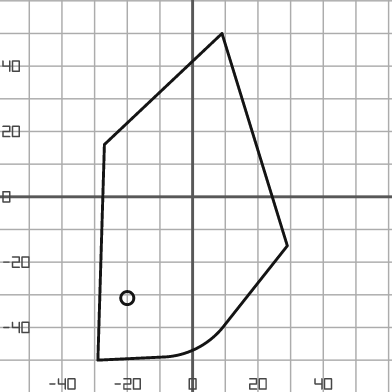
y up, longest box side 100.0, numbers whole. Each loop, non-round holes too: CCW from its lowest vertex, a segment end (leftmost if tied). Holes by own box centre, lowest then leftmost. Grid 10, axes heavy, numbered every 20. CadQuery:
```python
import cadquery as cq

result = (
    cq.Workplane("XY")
    .moveTo(-29.0, -50.0)
    .lineTo(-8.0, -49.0)
    .threePointArc((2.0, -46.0), (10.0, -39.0))
    .lineTo(29.0, -15.0)
    .lineTo(9.0, 50.0)
    .lineTo(-27.0, 16.0)
    .close()
    .moveTo(-20.0, -31.0)
    .circle(2.0)
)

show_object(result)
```